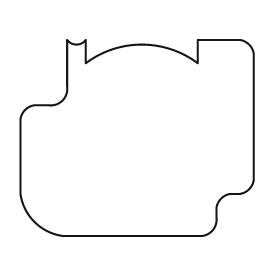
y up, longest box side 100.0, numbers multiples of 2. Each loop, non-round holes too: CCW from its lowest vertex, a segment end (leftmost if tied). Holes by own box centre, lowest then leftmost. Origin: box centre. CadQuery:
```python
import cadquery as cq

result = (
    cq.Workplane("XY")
    .moveTo(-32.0, -42.0)
    .lineTo(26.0, -42.0)
    .threePointArc((32.0, -40.0), (34.0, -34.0))
    .lineTo(34.0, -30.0)
    .threePointArc((36.0, -26.0), (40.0, -24.0))
    .lineTo(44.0, -24.0)
    .threePointArc((48.0, -22.0), (50.0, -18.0))
    .lineTo(50.0, 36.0)
    .threePointArc((48.0, 40.0), (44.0, 42.0))
    .lineTo(26.0, 42.0)
    .lineTo(26.0, 32.0)
    .threePointArc((2.0, 40.0), (-22.0, 32.0))
    .lineTo(-22.0, 42.0)
    .threePointArc((-26.0, 40.0), (-30.0, 42.0))
    .lineTo(-30.0, 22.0)
    .threePointArc((-32.0, 16.0), (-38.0, 14.0))
    .lineTo(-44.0, 14.0)
    .threePointArc((-48.0, 12.0), (-50.0, 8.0))
    .lineTo(-50.0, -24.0)
    .threePointArc((-44.0, -36.0), (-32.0, -42.0))
    .close()
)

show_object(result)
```